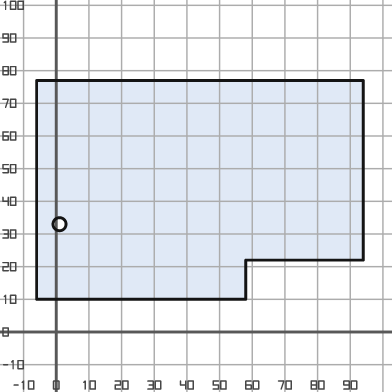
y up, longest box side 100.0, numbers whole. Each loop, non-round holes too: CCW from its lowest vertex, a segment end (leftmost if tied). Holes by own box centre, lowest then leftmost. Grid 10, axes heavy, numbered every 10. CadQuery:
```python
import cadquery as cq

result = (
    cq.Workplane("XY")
    .moveTo(-6.0, 10.0)
    .lineTo(58.0, 10.0)
    .lineTo(58.0, 22.0)
    .lineTo(94.0, 22.0)
    .lineTo(94.0, 77.0)
    .lineTo(-6.0, 77.0)
    .close()
    .moveTo(1.0, 33.0)
    .circle(2.0)
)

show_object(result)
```